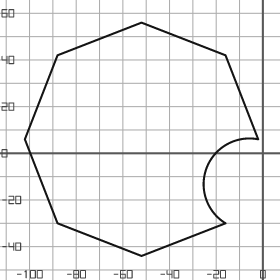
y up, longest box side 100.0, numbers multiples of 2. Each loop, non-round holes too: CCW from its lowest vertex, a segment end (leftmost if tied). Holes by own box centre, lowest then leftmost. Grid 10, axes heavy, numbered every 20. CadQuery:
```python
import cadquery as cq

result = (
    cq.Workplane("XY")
    .moveTo(-52.0, -44.0)
    .lineTo(-16.0, -30.0)
    .threePointArc((-24.0, -6.0), (-2.0, 6.0))
    .lineTo(-16.0, 42.0)
    .lineTo(-52.0, 56.0)
    .lineTo(-88.0, 42.0)
    .lineTo(-102.0, 6.0)
    .lineTo(-88.0, -30.0)
    .close()
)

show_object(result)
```